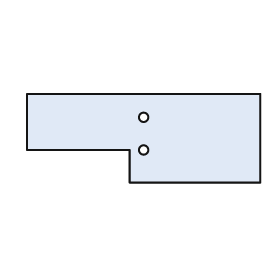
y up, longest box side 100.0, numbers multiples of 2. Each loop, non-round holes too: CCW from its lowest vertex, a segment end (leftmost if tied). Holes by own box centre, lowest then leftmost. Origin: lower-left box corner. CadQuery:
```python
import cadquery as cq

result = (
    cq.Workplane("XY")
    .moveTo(44.0, 0.0)
    .lineTo(100.0, 0.0)
    .lineTo(100.0, 38.0)
    .lineTo(0.0, 38.0)
    .lineTo(0.0, 14.0)
    .lineTo(44.0, 14.0)
    .close()
    .moveTo(50.0, 14.0)
    .circle(2.0)
    .moveTo(50.0, 28.0)
    .circle(2.0)
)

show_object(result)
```